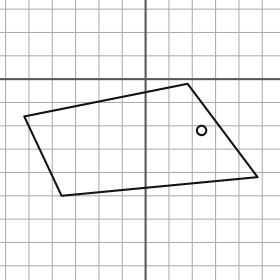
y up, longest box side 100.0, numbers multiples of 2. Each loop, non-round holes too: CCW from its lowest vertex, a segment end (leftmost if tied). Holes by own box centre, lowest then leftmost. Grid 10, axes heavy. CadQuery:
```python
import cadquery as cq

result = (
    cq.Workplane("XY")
    .moveTo(-36.0, -50.0)
    .lineTo(48.0, -42.0)
    .lineTo(18.0, -2.0)
    .lineTo(-52.0, -16.0)
    .close()
    .moveTo(24.0, -22.0)
    .circle(2.0)
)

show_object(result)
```